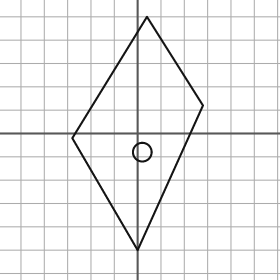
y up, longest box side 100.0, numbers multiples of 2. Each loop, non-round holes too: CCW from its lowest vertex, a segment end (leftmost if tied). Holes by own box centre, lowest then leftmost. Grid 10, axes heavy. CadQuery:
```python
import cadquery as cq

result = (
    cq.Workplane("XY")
    .moveTo(0.0, -50.0)
    .lineTo(28.0, 12.0)
    .lineTo(4.0, 50.0)
    .lineTo(-28.0, -2.0)
    .close()
    .moveTo(2.0, -8.0)
    .circle(4.0)
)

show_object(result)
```